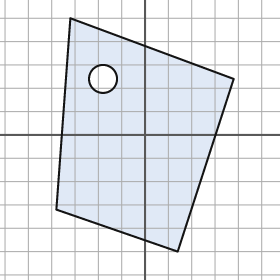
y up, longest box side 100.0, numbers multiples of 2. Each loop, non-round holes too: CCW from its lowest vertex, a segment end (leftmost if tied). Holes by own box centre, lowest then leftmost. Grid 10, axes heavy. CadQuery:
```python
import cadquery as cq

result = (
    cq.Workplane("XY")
    .moveTo(14.0, -50.0)
    .lineTo(38.0, 24.0)
    .lineTo(-32.0, 50.0)
    .lineTo(-38.0, -32.0)
    .close()
    .moveTo(-18.0, 24.0)
    .circle(6.0)
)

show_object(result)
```